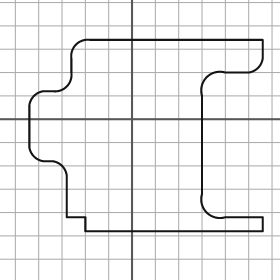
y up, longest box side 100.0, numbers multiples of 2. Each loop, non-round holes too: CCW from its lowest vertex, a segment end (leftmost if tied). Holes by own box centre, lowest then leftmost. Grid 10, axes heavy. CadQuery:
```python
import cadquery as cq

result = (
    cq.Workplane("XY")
    .moveTo(-20.0, -48.0)
    .lineTo(56.0, -48.0)
    .lineTo(56.0, -42.0)
    .lineTo(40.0, -42.0)
    .threePointArc((32.0, -40.0), (30.0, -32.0))
    .lineTo(30.0, 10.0)
    .threePointArc((32.0, 18.0), (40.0, 20.0))
    .lineTo(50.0, 20.0)
    .threePointArc((54.0, 22.0), (56.0, 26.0))
    .lineTo(56.0, 34.0)
    .lineTo(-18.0, 34.0)
    .threePointArc((-24.0, 32.0), (-26.0, 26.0))
    .lineTo(-26.0, 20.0)
    .threePointArc((-28.0, 14.0), (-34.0, 12.0))
    .lineTo(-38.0, 12.0)
    .threePointArc((-42.0, 10.0), (-44.0, 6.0))
    .lineTo(-44.0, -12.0)
    .threePointArc((-42.0, -16.0), (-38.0, -18.0))
    .lineTo(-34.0, -18.0)
    .threePointArc((-30.0, -20.0), (-28.0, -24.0))
    .lineTo(-28.0, -42.0)
    .lineTo(-20.0, -42.0)
    .close()
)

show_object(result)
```